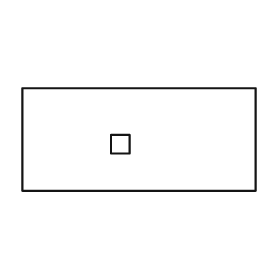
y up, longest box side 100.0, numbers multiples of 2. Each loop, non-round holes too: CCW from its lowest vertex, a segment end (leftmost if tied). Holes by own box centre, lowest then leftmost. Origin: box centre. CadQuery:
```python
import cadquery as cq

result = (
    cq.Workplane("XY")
    .moveTo(-50.0, -22.0)
    .lineTo(50.0, -22.0)
    .lineTo(50.0, 22.0)
    .lineTo(-50.0, 22.0)
    .close()
    .moveTo(-12.0, -6.0)
    .lineTo(-4.0, -6.0)
    .lineTo(-4.0, 2.0)
    .lineTo(-12.0, 2.0)
    .close()
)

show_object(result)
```